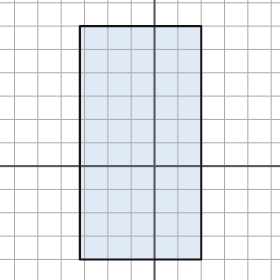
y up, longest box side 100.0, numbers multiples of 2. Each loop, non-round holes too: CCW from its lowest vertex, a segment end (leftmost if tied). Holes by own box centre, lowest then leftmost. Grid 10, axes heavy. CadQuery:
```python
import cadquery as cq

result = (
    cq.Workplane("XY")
    .moveTo(-32.0, -40.0)
    .lineTo(20.0, -40.0)
    .lineTo(20.0, 60.0)
    .lineTo(-32.0, 60.0)
    .close()
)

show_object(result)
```